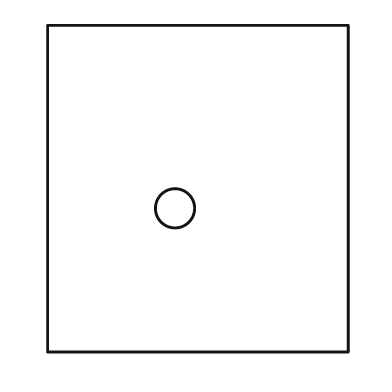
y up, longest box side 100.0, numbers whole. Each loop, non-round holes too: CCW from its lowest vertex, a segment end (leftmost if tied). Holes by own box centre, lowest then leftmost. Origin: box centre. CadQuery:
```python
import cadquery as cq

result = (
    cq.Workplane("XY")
    .moveTo(-46.0, -50.0)
    .lineTo(46.0, -50.0)
    .lineTo(46.0, 50.0)
    .lineTo(-46.0, 50.0)
    .close()
    .moveTo(-7.0, -6.0)
    .circle(6.0)
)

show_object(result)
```